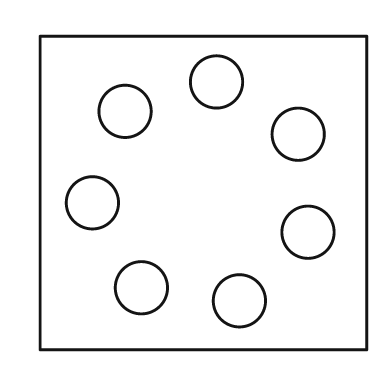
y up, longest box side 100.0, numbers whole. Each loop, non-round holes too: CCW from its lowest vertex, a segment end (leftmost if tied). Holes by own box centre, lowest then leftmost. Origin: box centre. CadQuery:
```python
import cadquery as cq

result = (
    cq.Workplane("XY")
    .moveTo(-50.0, -48.0)
    .lineTo(50.0, -48.0)
    .lineTo(50.0, 48.0)
    .lineTo(-50.0, 48.0)
    .close()
    .moveTo(11.0, -33.0)
    .circle(8.0)
    .moveTo(-19.0, -29.0)
    .circle(8.0)
    .moveTo(32.0, -12.0)
    .circle(8.0)
    .moveTo(-34.0, -3.0)
    .circle(8.0)
    .moveTo(29.0, 18.0)
    .circle(8.0)
    .moveTo(-24.0, 25.0)
    .circle(8.0)
    .moveTo(4.0, 34.0)
    .circle(8.0)
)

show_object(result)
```